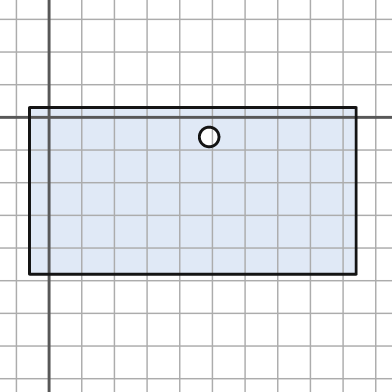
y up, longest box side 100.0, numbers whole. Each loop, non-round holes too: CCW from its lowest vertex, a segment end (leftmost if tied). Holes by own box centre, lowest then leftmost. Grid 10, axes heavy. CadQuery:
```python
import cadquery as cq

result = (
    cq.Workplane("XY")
    .moveTo(-6.0, -48.0)
    .lineTo(94.0, -48.0)
    .lineTo(94.0, 3.0)
    .lineTo(-6.0, 3.0)
    .close()
    .moveTo(49.0, -6.0)
    .circle(3.0)
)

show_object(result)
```